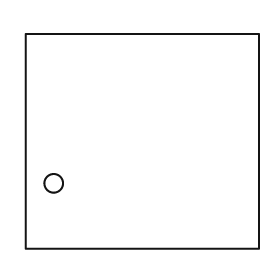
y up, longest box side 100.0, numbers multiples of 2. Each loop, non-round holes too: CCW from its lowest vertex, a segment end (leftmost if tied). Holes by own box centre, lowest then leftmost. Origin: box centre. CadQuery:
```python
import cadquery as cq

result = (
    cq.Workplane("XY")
    .moveTo(-50.0, -46.0)
    .lineTo(50.0, -46.0)
    .lineTo(50.0, 46.0)
    .lineTo(-50.0, 46.0)
    .close()
    .moveTo(-38.0, -18.0)
    .circle(4.0)
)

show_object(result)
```